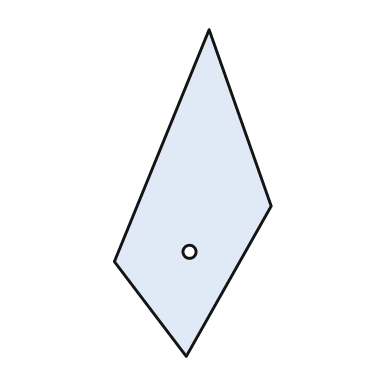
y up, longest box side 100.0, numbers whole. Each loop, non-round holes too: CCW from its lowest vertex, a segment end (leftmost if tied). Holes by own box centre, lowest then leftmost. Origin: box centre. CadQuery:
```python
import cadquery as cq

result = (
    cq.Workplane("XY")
    .moveTo(-2.0, -50.0)
    .lineTo(24.0, -4.0)
    .lineTo(5.0, 50.0)
    .lineTo(-24.0, -21.0)
    .close()
    .moveTo(-1.0, -18.0)
    .circle(2.0)
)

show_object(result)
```